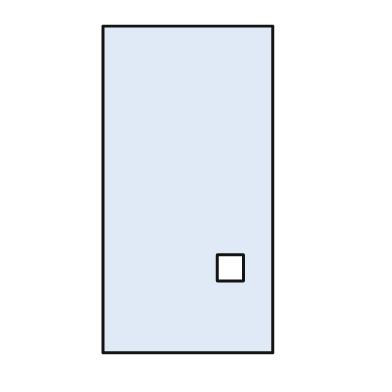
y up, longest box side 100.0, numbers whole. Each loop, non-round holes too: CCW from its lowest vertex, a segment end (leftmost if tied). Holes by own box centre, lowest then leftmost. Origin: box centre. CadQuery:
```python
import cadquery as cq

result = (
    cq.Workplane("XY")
    .moveTo(-26.0, -50.0)
    .lineTo(26.0, -50.0)
    .lineTo(26.0, 50.0)
    .lineTo(-26.0, 50.0)
    .close()
    .moveTo(9.0, -28.0)
    .lineTo(17.0, -28.0)
    .lineTo(17.0, -20.0)
    .lineTo(9.0, -20.0)
    .close()
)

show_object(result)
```